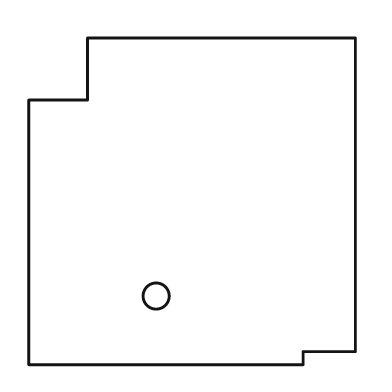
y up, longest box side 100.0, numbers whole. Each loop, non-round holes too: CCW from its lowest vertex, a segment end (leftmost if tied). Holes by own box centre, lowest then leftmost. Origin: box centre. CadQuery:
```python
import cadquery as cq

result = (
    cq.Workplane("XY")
    .moveTo(-50.0, -50.0)
    .lineTo(34.0, -50.0)
    .lineTo(34.0, -46.0)
    .lineTo(50.0, -46.0)
    .lineTo(50.0, 50.0)
    .lineTo(-32.0, 50.0)
    .lineTo(-32.0, 31.0)
    .lineTo(-50.0, 31.0)
    .close()
    .moveTo(-11.0, -29.0)
    .circle(4.0)
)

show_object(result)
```